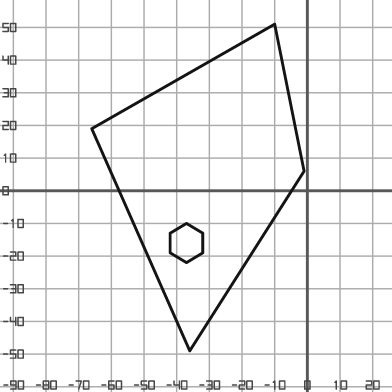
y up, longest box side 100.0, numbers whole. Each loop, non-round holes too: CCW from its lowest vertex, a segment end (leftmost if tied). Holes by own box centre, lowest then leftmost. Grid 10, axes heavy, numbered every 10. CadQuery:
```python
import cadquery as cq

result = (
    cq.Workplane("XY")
    .moveTo(-36.0, -49.0)
    .lineTo(-1.0, 6.0)
    .lineTo(-10.0, 51.0)
    .lineTo(-66.0, 19.0)
    .close()
    .moveTo(-37.0, -22.0)
    .lineTo(-32.0, -19.0)
    .lineTo(-32.0, -13.0)
    .lineTo(-37.0, -10.0)
    .lineTo(-42.0, -13.0)
    .lineTo(-42.0, -19.0)
    .close()
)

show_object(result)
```